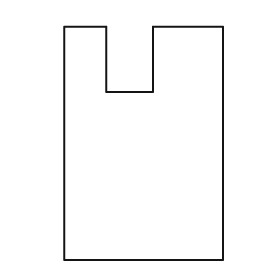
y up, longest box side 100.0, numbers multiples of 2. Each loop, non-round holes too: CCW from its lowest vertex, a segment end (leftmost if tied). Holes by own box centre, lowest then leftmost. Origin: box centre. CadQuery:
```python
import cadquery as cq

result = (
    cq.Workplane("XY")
    .moveTo(-34.0, -50.0)
    .lineTo(34.0, -50.0)
    .lineTo(34.0, 50.0)
    .lineTo(4.0, 50.0)
    .lineTo(4.0, 22.0)
    .lineTo(-16.0, 22.0)
    .lineTo(-16.0, 50.0)
    .lineTo(-34.0, 50.0)
    .close()
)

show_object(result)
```